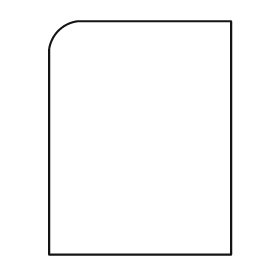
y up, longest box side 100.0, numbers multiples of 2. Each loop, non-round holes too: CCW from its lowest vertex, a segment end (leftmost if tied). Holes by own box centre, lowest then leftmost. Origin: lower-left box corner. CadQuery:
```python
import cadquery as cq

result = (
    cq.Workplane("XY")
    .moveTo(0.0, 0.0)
    .lineTo(78.0, 0.0)
    .lineTo(78.0, 100.0)
    .lineTo(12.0, 100.0)
    .threePointArc((4.0, 96.0), (0.0, 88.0))
    .close()
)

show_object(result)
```